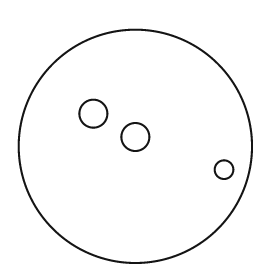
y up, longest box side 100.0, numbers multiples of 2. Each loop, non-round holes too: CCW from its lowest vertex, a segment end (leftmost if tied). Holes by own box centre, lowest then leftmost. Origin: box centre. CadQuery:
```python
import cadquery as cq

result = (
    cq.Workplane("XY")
    .moveTo(0.0, 0.0)
    .circle(50.0)
    .moveTo(38.0, -10.0)
    .circle(4.0)
    .moveTo(0.0, 4.0)
    .circle(6.0)
    .moveTo(-18.0, 14.0)
    .circle(6.0)
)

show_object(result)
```